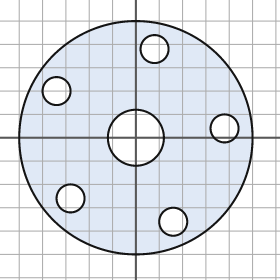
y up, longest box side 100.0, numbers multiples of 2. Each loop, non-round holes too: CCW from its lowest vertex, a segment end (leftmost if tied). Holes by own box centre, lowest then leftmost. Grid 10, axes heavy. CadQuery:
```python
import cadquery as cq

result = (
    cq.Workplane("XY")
    .moveTo(0.0, 0.0)
    .circle(50.0)
    .moveTo(16.0, -36.0)
    .circle(6.0)
    .moveTo(-28.0, -26.0)
    .circle(6.0)
    .moveTo(0.0, 0.0)
    .circle(12.0)
    .moveTo(38.0, 4.0)
    .circle(6.0)
    .moveTo(-34.0, 20.0)
    .circle(6.0)
    .moveTo(8.0, 38.0)
    .circle(6.0)
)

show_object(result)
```